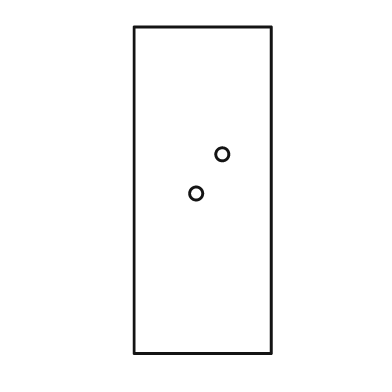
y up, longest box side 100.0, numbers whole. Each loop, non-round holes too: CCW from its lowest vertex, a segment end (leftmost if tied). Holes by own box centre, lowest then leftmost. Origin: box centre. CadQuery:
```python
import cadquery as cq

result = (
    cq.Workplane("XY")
    .moveTo(-21.0, -50.0)
    .lineTo(21.0, -50.0)
    .lineTo(21.0, 50.0)
    .lineTo(-21.0, 50.0)
    .close()
    .moveTo(-2.0, -1.0)
    .circle(2.0)
    .moveTo(6.0, 11.0)
    .circle(2.0)
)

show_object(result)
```